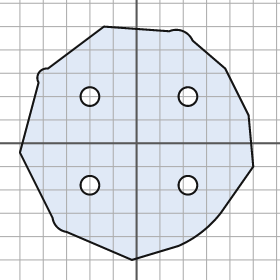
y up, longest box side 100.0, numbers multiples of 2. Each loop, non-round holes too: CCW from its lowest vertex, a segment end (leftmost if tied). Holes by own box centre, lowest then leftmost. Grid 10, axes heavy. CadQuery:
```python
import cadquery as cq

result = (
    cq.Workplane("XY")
    .moveTo(-2.0, -50.0)
    .lineTo(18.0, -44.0)
    .threePointArc((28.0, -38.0), (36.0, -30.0))
    .lineTo(50.0, -10.0)
    .lineTo(48.0, 12.0)
    .lineTo(38.0, 32.0)
    .lineTo(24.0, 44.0)
    .threePointArc((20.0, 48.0), (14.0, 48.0))
    .lineTo(-14.0, 50.0)
    .lineTo(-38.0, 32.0)
    .threePointArc((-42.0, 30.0), (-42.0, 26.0))
    .lineTo(-50.0, -4.0)
    .lineTo(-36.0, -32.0)
    .threePointArc((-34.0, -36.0), (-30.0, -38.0))
    .close()
    .moveTo(-20.0, -18.0)
    .circle(4.0)
    .moveTo(22.0, -18.0)
    .circle(4.0)
    .moveTo(-20.0, 20.0)
    .circle(4.0)
    .moveTo(22.0, 20.0)
    .circle(4.0)
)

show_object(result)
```